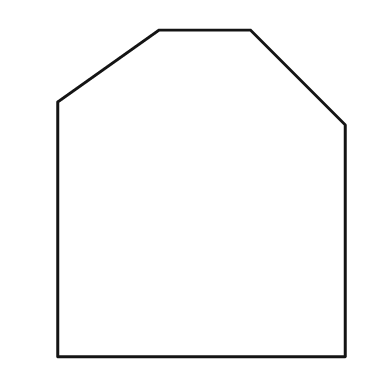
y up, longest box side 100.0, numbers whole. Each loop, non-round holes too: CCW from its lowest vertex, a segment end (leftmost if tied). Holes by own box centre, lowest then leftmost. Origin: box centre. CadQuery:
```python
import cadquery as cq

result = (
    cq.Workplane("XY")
    .moveTo(-44.0, -50.0)
    .lineTo(44.0, -50.0)
    .lineTo(44.0, 21.0)
    .lineTo(15.0, 50.0)
    .lineTo(-13.0, 50.0)
    .lineTo(-44.0, 28.0)
    .close()
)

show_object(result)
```